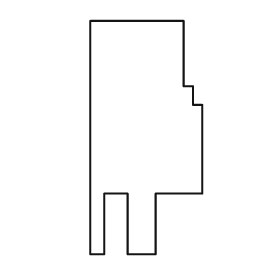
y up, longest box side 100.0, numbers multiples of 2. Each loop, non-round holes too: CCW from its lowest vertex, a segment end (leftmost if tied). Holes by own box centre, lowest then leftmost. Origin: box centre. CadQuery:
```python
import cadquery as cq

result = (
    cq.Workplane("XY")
    .moveTo(-24.0, -50.0)
    .lineTo(-18.0, -50.0)
    .lineTo(-18.0, -24.0)
    .lineTo(-8.0, -24.0)
    .lineTo(-8.0, -50.0)
    .lineTo(4.0, -50.0)
    .lineTo(4.0, -24.0)
    .lineTo(24.0, -24.0)
    .lineTo(24.0, 14.0)
    .lineTo(20.0, 14.0)
    .lineTo(20.0, 22.0)
    .lineTo(16.0, 22.0)
    .lineTo(16.0, 50.0)
    .lineTo(-24.0, 50.0)
    .close()
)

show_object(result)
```